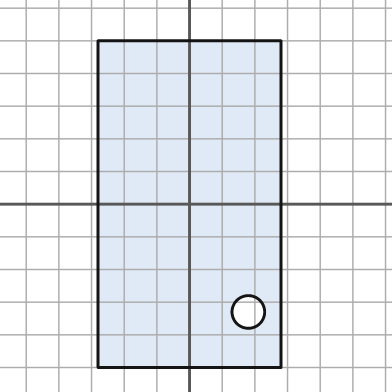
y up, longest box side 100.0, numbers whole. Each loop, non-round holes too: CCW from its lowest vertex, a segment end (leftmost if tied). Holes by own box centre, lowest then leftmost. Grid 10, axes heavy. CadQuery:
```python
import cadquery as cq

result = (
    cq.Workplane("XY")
    .moveTo(-28.0, -50.0)
    .lineTo(28.0, -50.0)
    .lineTo(28.0, 50.0)
    .lineTo(-28.0, 50.0)
    .close()
    .moveTo(18.0, -33.0)
    .circle(5.0)
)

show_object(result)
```